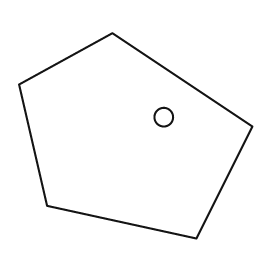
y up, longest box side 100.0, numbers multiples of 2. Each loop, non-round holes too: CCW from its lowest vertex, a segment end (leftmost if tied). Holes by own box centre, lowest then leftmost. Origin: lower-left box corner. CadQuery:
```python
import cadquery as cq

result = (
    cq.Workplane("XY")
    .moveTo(76.0, 0.0)
    .lineTo(100.0, 48.0)
    .lineTo(40.0, 88.0)
    .lineTo(0.0, 66.0)
    .lineTo(12.0, 14.0)
    .close()
    .moveTo(62.0, 52.0)
    .circle(4.0)
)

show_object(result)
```